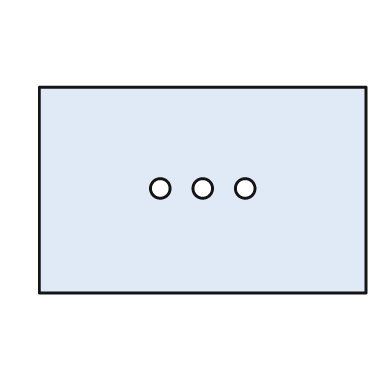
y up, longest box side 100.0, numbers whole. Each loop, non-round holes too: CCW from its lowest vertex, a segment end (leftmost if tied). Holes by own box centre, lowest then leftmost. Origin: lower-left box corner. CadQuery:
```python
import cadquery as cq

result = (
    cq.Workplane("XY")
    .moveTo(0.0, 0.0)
    .lineTo(100.0, 0.0)
    .lineTo(100.0, 63.0)
    .lineTo(0.0, 63.0)
    .close()
    .moveTo(37.0, 32.0)
    .circle(3.0)
    .moveTo(50.0, 32.0)
    .circle(3.0)
    .moveTo(63.0, 32.0)
    .circle(3.0)
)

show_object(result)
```